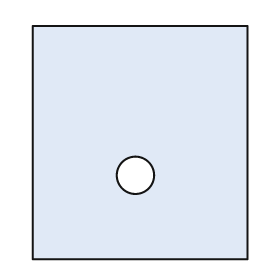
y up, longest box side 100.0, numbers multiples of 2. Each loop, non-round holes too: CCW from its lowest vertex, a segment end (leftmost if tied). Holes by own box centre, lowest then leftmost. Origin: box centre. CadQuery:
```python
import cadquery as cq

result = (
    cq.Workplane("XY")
    .moveTo(-46.0, -50.0)
    .lineTo(46.0, -50.0)
    .lineTo(46.0, 50.0)
    .lineTo(-46.0, 50.0)
    .close()
    .moveTo(-2.0, -14.0)
    .circle(8.0)
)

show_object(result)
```